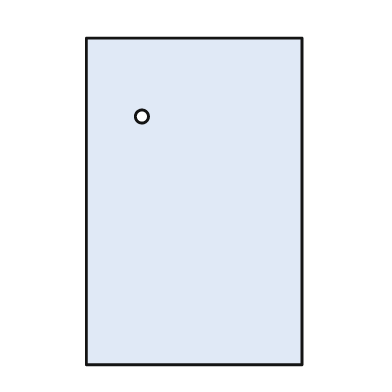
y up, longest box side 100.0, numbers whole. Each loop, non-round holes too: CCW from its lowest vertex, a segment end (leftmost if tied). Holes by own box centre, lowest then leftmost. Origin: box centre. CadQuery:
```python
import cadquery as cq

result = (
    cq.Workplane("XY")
    .moveTo(-33.0, -50.0)
    .lineTo(33.0, -50.0)
    .lineTo(33.0, 50.0)
    .lineTo(-33.0, 50.0)
    .close()
    .moveTo(-16.0, 26.0)
    .circle(2.0)
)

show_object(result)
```